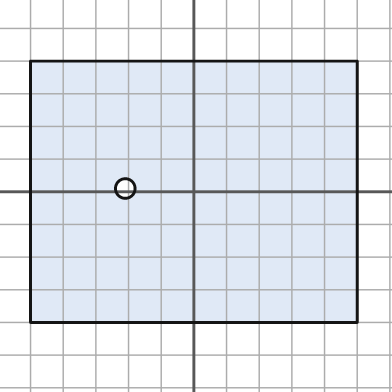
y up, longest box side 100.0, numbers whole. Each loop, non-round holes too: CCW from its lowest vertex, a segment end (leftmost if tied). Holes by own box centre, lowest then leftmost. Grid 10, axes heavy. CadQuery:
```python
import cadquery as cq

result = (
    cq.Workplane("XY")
    .moveTo(-50.0, -40.0)
    .lineTo(50.0, -40.0)
    .lineTo(50.0, 40.0)
    .lineTo(-50.0, 40.0)
    .close()
    .moveTo(-21.0, 1.0)
    .circle(3.0)
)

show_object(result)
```